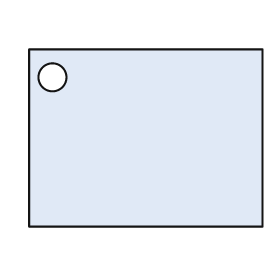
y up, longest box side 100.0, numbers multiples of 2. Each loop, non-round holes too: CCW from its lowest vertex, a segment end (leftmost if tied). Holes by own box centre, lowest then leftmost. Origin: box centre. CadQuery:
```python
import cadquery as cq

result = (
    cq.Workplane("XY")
    .moveTo(-50.0, -38.0)
    .lineTo(50.0, -38.0)
    .lineTo(50.0, 38.0)
    .lineTo(-50.0, 38.0)
    .close()
    .moveTo(-40.0, 26.0)
    .circle(6.0)
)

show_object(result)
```